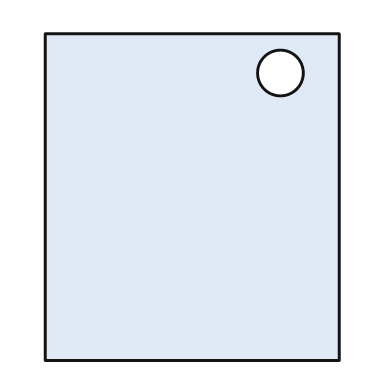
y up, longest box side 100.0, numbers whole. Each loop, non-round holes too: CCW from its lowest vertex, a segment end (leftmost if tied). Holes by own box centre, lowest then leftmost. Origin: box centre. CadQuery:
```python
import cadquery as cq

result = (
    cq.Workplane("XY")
    .moveTo(-45.0, -50.0)
    .lineTo(45.0, -50.0)
    .lineTo(45.0, 50.0)
    .lineTo(-45.0, 50.0)
    .close()
    .moveTo(27.0, 38.0)
    .circle(7.0)
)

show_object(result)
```